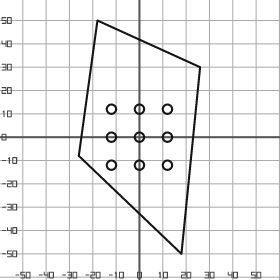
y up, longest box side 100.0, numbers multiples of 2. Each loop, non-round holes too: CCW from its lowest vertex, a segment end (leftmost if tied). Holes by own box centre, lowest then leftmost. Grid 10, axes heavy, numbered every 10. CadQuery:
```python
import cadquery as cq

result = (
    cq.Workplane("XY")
    .moveTo(18.0, -50.0)
    .lineTo(26.0, 30.0)
    .lineTo(-18.0, 50.0)
    .lineTo(-26.0, -8.0)
    .close()
    .moveTo(-12.0, -12.0)
    .circle(2.0)
    .moveTo(0.0, -12.0)
    .circle(2.0)
    .moveTo(12.0, -12.0)
    .circle(2.0)
    .moveTo(-12.0, 0.0)
    .circle(2.0)
    .moveTo(0.0, 0.0)
    .circle(2.0)
    .moveTo(12.0, 0.0)
    .circle(2.0)
    .moveTo(-12.0, 12.0)
    .circle(2.0)
    .moveTo(0.0, 12.0)
    .circle(2.0)
    .moveTo(12.0, 12.0)
    .circle(2.0)
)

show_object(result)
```